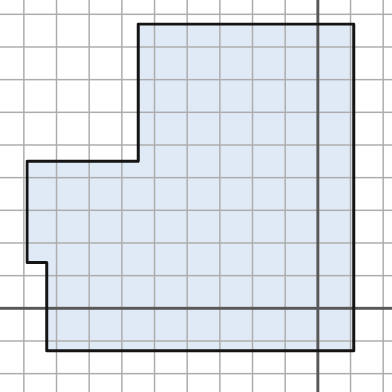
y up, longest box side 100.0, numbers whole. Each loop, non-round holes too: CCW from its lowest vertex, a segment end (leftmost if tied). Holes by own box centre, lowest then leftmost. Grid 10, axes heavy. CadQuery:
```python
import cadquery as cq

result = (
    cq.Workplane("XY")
    .moveTo(-83.0, -13.0)
    .lineTo(11.0, -13.0)
    .lineTo(11.0, 87.0)
    .lineTo(-55.0, 87.0)
    .lineTo(-55.0, 45.0)
    .lineTo(-89.0, 45.0)
    .lineTo(-89.0, 14.0)
    .lineTo(-83.0, 14.0)
    .close()
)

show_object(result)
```